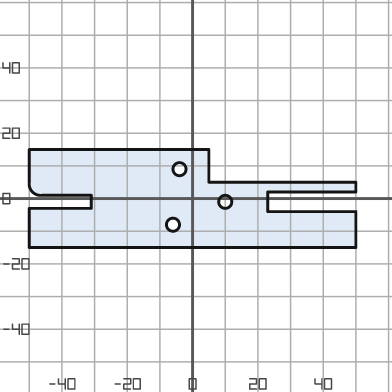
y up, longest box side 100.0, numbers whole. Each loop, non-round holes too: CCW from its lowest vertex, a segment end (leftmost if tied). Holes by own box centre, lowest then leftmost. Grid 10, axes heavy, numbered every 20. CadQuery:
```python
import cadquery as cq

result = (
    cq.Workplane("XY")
    .moveTo(-50.0, -15.0)
    .lineTo(50.0, -15.0)
    .lineTo(50.0, -4.0)
    .lineTo(23.0, -4.0)
    .lineTo(23.0, 2.0)
    .lineTo(50.0, 2.0)
    .lineTo(50.0, 5.0)
    .lineTo(5.0, 5.0)
    .lineTo(5.0, 15.0)
    .lineTo(-50.0, 15.0)
    .lineTo(-50.0, 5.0)
    .threePointArc((-49.0, 2.0), (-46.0, 1.0))
    .lineTo(-31.0, 1.0)
    .lineTo(-31.0, -3.0)
    .lineTo(-50.0, -3.0)
    .close()
    .moveTo(-6.0, -8.0)
    .circle(2.0)
    .moveTo(10.0, -1.0)
    .circle(2.0)
    .moveTo(-4.0, 9.0)
    .circle(2.0)
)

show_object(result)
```